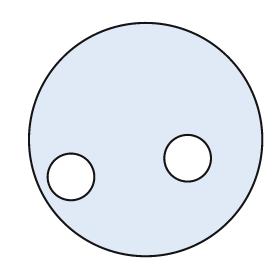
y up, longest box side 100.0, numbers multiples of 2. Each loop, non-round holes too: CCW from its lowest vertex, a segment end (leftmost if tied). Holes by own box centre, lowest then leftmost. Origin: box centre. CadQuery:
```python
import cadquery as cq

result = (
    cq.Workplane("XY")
    .moveTo(0.0, 0.0)
    .circle(50.0)
    .moveTo(-32.0, -16.0)
    .circle(10.0)
    .moveTo(18.0, -8.0)
    .circle(10.0)
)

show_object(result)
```